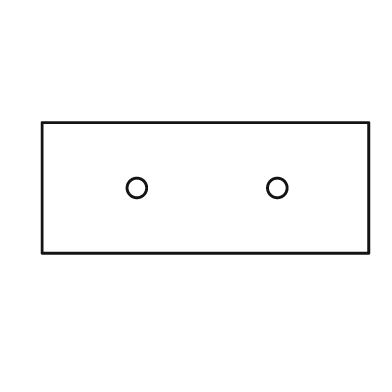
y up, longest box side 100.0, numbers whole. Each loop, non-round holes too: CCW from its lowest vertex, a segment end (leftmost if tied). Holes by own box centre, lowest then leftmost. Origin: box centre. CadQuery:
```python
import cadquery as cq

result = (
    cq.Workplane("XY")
    .moveTo(-50.0, -20.0)
    .lineTo(50.0, -20.0)
    .lineTo(50.0, 20.0)
    .lineTo(-50.0, 20.0)
    .close()
    .moveTo(-21.0, 0.0)
    .circle(3.0)
    .moveTo(22.0, 0.0)
    .circle(3.0)
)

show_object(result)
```